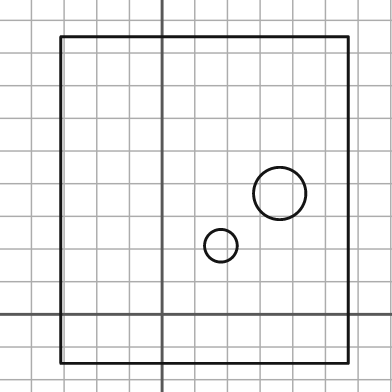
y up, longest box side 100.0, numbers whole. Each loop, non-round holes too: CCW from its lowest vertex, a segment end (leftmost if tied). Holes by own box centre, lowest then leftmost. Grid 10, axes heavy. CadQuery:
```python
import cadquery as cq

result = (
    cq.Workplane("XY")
    .moveTo(-31.0, -15.0)
    .lineTo(57.0, -15.0)
    .lineTo(57.0, 85.0)
    .lineTo(-31.0, 85.0)
    .close()
    .moveTo(18.0, 21.0)
    .circle(5.0)
    .moveTo(36.0, 37.0)
    .circle(8.0)
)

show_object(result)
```